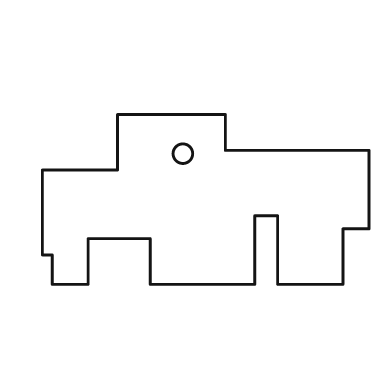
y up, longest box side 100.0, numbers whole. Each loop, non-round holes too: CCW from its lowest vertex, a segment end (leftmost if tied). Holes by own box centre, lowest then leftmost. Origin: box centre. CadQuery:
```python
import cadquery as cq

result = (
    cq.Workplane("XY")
    .moveTo(-47.0, -26.0)
    .lineTo(-36.0, -26.0)
    .lineTo(-36.0, -12.0)
    .lineTo(-17.0, -12.0)
    .lineTo(-17.0, -26.0)
    .lineTo(15.0, -26.0)
    .lineTo(15.0, -5.0)
    .lineTo(22.0, -5.0)
    .lineTo(22.0, -26.0)
    .lineTo(42.0, -26.0)
    .lineTo(42.0, -9.0)
    .lineTo(50.0, -9.0)
    .lineTo(50.0, 15.0)
    .lineTo(6.0, 15.0)
    .lineTo(6.0, 26.0)
    .lineTo(-27.0, 26.0)
    .lineTo(-27.0, 9.0)
    .lineTo(-50.0, 9.0)
    .lineTo(-50.0, -17.0)
    .lineTo(-47.0, -17.0)
    .close()
    .moveTo(-7.0, 14.0)
    .circle(3.0)
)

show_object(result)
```